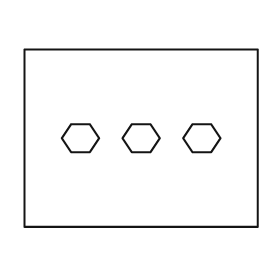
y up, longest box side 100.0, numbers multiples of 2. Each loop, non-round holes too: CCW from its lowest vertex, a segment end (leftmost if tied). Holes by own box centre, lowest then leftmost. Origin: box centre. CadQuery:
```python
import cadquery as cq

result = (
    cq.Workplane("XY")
    .moveTo(-50.0, -38.0)
    .lineTo(50.0, -38.0)
    .lineTo(50.0, 38.0)
    .lineTo(-50.0, 38.0)
    .close()
    .moveTo(-30.0, -6.0)
    .lineTo(-22.0, -6.0)
    .lineTo(-18.0, 0.0)
    .lineTo(-22.0, 6.0)
    .lineTo(-30.0, 6.0)
    .lineTo(-34.0, 0.0)
    .close()
    .moveTo(-4.0, -6.0)
    .lineTo(4.0, -6.0)
    .lineTo(8.0, 0.0)
    .lineTo(4.0, 6.0)
    .lineTo(-4.0, 6.0)
    .lineTo(-8.0, 0.0)
    .close()
    .moveTo(22.0, -6.0)
    .lineTo(30.0, -6.0)
    .lineTo(34.0, 0.0)
    .lineTo(30.0, 6.0)
    .lineTo(22.0, 6.0)
    .lineTo(18.0, 0.0)
    .close()
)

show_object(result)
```